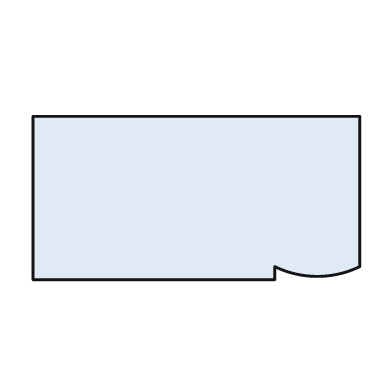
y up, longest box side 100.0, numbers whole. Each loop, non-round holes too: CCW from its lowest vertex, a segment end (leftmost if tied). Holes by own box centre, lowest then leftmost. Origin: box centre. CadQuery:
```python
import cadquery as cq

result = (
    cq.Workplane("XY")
    .moveTo(-50.0, -25.0)
    .lineTo(24.0, -25.0)
    .lineTo(24.0, -21.0)
    .threePointArc((37.0, -24.0), (50.0, -21.0))
    .lineTo(50.0, 25.0)
    .lineTo(-50.0, 25.0)
    .close()
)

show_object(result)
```